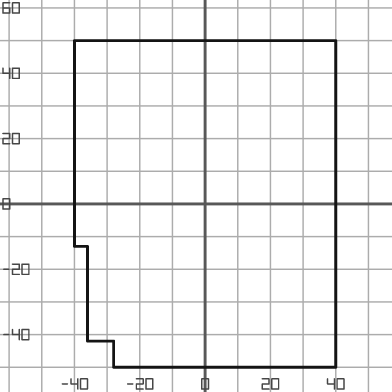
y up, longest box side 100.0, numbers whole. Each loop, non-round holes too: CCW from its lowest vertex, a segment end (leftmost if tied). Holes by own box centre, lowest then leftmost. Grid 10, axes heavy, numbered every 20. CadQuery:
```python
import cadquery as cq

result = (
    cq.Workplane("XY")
    .moveTo(-28.0, -50.0)
    .lineTo(40.0, -50.0)
    .lineTo(40.0, 50.0)
    .lineTo(-40.0, 50.0)
    .lineTo(-40.0, -13.0)
    .lineTo(-36.0, -13.0)
    .lineTo(-36.0, -42.0)
    .lineTo(-28.0, -42.0)
    .close()
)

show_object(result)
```